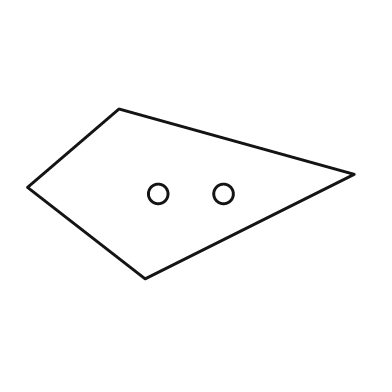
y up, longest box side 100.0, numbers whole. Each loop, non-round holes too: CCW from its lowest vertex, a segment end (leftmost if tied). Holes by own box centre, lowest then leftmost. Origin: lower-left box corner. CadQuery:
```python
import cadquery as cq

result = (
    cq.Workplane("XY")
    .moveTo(36.0, 0.0)
    .lineTo(100.0, 32.0)
    .lineTo(28.0, 52.0)
    .lineTo(0.0, 28.0)
    .close()
    .moveTo(40.0, 26.0)
    .circle(3.0)
    .moveTo(60.0, 26.0)
    .circle(3.0)
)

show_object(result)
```